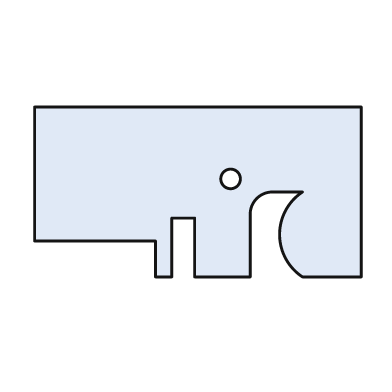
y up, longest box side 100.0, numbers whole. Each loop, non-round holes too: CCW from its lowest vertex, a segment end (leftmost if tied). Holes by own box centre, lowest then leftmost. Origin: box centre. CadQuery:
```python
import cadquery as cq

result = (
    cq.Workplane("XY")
    .moveTo(-13.0, -26.0)
    .lineTo(-8.0, -26.0)
    .lineTo(-8.0, -8.0)
    .lineTo(-1.0, -8.0)
    .lineTo(-1.0, -26.0)
    .lineTo(16.0, -26.0)
    .lineTo(16.0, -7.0)
    .threePointArc((18.0, -2.0), (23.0, 0.0))
    .lineTo(32.0, 0.0)
    .threePointArc((25.0, -13.0), (32.0, -26.0))
    .lineTo(50.0, -26.0)
    .lineTo(50.0, 26.0)
    .lineTo(-50.0, 26.0)
    .lineTo(-50.0, -15.0)
    .lineTo(-13.0, -15.0)
    .close()
    .moveTo(10.0, 4.0)
    .circle(3.0)
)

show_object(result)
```